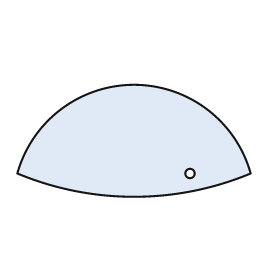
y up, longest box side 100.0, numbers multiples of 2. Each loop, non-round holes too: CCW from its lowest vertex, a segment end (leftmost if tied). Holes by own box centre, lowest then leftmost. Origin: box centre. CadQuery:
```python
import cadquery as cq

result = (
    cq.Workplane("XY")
    .moveTo(-50.0, -14.0)
    .threePointArc((0.0, -24.0), (50.0, -14.0))
    .threePointArc((0.0, 24.0), (-50.0, -14.0))
    .close()
    .moveTo(24.0, -14.0)
    .circle(2.0)
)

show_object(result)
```